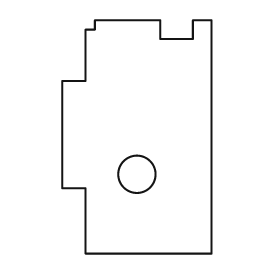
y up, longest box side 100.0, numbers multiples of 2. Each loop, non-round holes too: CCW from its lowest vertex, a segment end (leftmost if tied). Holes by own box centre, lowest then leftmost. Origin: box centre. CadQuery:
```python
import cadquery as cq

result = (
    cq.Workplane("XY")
    .moveTo(-22.0, -50.0)
    .lineTo(32.0, -50.0)
    .lineTo(32.0, 50.0)
    .lineTo(24.0, 50.0)
    .lineTo(24.0, 42.0)
    .lineTo(10.0, 42.0)
    .lineTo(10.0, 50.0)
    .lineTo(-18.0, 50.0)
    .lineTo(-18.0, 46.0)
    .lineTo(-22.0, 46.0)
    .lineTo(-22.0, 24.0)
    .lineTo(-32.0, 24.0)
    .lineTo(-32.0, -22.0)
    .lineTo(-22.0, -22.0)
    .close()
    .moveTo(0.0, -16.0)
    .circle(8.0)
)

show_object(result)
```